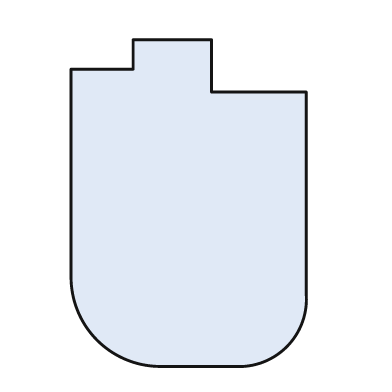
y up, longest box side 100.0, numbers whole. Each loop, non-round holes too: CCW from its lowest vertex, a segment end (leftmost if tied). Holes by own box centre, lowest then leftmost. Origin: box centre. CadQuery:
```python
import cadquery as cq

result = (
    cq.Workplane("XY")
    .moveTo(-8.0, -50.0)
    .lineTo(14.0, -50.0)
    .threePointArc((30.0, -44.0), (36.0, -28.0))
    .lineTo(36.0, 34.0)
    .lineTo(7.0, 34.0)
    .lineTo(7.0, 50.0)
    .lineTo(-17.0, 50.0)
    .lineTo(-17.0, 41.0)
    .lineTo(-36.0, 41.0)
    .lineTo(-36.0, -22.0)
    .threePointArc((-28.0, -42.0), (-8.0, -50.0))
    .close()
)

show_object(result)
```